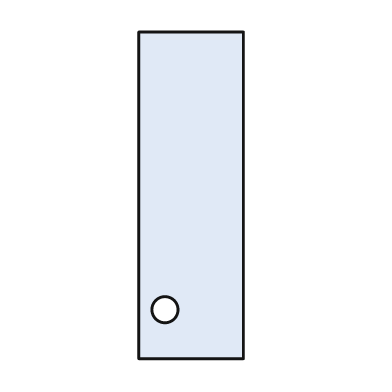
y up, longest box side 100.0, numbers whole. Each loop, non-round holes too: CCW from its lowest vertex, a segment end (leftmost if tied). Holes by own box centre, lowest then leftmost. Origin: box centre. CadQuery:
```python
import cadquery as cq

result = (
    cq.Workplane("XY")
    .moveTo(-16.0, -50.0)
    .lineTo(16.0, -50.0)
    .lineTo(16.0, 50.0)
    .lineTo(-16.0, 50.0)
    .close()
    .moveTo(-8.0, -35.0)
    .circle(4.0)
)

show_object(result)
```